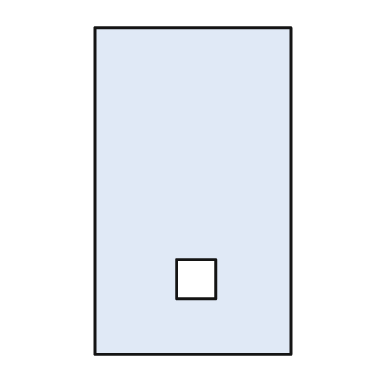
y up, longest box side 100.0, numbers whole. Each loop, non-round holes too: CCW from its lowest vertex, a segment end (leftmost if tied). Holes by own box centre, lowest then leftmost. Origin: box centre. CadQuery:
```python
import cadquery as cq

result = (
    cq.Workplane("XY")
    .moveTo(-30.0, -50.0)
    .lineTo(30.0, -50.0)
    .lineTo(30.0, 50.0)
    .lineTo(-30.0, 50.0)
    .close()
    .moveTo(-5.0, -33.0)
    .lineTo(7.0, -33.0)
    .lineTo(7.0, -21.0)
    .lineTo(-5.0, -21.0)
    .close()
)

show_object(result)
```